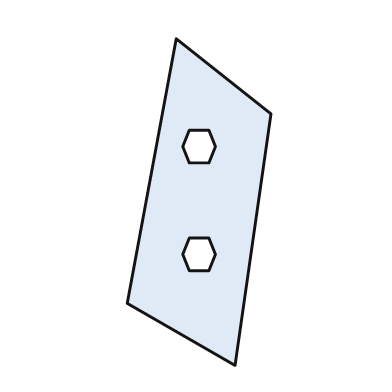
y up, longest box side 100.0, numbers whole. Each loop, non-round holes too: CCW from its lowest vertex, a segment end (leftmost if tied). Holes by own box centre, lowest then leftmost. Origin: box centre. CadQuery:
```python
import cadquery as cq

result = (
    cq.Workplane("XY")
    .moveTo(11.0, -50.0)
    .lineTo(22.0, 27.0)
    .lineTo(-7.0, 50.0)
    .lineTo(-22.0, -31.0)
    .close()
    .moveTo(-3.0, -21.0)
    .lineTo(3.0, -21.0)
    .lineTo(5.0, -16.0)
    .lineTo(3.0, -11.0)
    .lineTo(-3.0, -11.0)
    .lineTo(-5.0, -16.0)
    .close()
    .moveTo(-3.0, 12.0)
    .lineTo(3.0, 12.0)
    .lineTo(5.0, 17.0)
    .lineTo(3.0, 22.0)
    .lineTo(-3.0, 22.0)
    .lineTo(-5.0, 17.0)
    .close()
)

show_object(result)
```